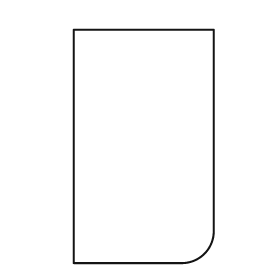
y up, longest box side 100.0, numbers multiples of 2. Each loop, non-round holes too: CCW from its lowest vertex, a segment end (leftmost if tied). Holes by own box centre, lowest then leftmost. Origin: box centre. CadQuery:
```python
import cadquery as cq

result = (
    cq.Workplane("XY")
    .moveTo(-30.0, -50.0)
    .lineTo(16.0, -50.0)
    .threePointArc((26.0, -46.0), (30.0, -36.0))
    .lineTo(30.0, 50.0)
    .lineTo(-30.0, 50.0)
    .close()
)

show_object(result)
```